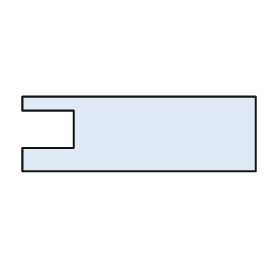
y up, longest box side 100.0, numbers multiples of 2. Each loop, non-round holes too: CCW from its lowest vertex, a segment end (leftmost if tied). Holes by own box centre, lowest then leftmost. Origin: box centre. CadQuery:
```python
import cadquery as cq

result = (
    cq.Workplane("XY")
    .moveTo(-50.0, -16.0)
    .lineTo(50.0, -16.0)
    .lineTo(50.0, 16.0)
    .lineTo(-50.0, 16.0)
    .lineTo(-50.0, 10.0)
    .lineTo(-28.0, 10.0)
    .lineTo(-28.0, -6.0)
    .lineTo(-50.0, -6.0)
    .close()
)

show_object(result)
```